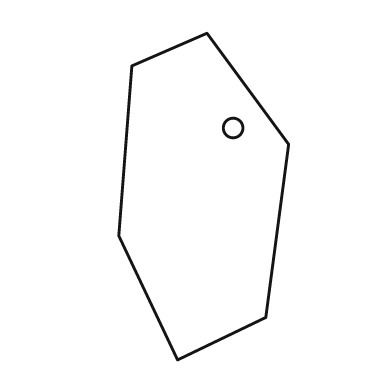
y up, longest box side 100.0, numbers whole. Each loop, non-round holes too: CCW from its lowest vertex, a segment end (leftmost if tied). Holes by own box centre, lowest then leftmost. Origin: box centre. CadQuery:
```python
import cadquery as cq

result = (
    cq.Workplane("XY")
    .moveTo(-8.0, -50.0)
    .lineTo(19.0, -37.0)
    .lineTo(26.0, 16.0)
    .lineTo(1.0, 50.0)
    .lineTo(-22.0, 40.0)
    .lineTo(-26.0, -12.0)
    .close()
    .moveTo(9.0, 21.0)
    .circle(3.0)
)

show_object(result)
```